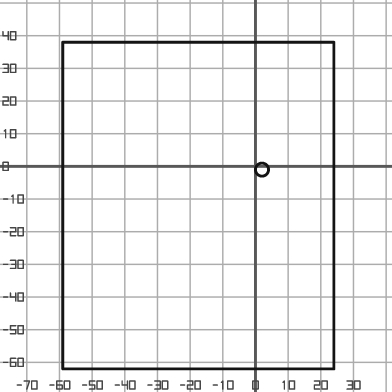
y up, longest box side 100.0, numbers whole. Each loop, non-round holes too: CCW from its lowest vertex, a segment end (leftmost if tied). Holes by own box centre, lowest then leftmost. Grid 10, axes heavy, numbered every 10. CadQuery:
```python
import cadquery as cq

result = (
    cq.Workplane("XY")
    .moveTo(-59.0, -62.0)
    .lineTo(24.0, -62.0)
    .lineTo(24.0, 38.0)
    .lineTo(-59.0, 38.0)
    .close()
    .moveTo(2.0, -1.0)
    .circle(2.0)
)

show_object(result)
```